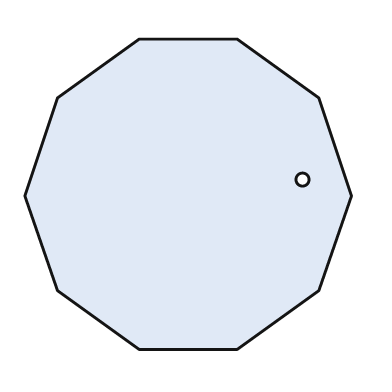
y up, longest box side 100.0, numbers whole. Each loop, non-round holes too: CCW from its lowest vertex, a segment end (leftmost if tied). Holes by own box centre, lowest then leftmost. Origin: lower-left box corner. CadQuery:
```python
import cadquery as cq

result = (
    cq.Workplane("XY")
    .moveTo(35.0, 0.0)
    .lineTo(65.0, 0.0)
    .lineTo(90.0, 18.0)
    .lineTo(100.0, 47.0)
    .lineTo(90.0, 77.0)
    .lineTo(65.0, 95.0)
    .lineTo(35.0, 95.0)
    .lineTo(10.0, 77.0)
    .lineTo(0.0, 47.0)
    .lineTo(10.0, 18.0)
    .close()
    .moveTo(85.0, 52.0)
    .circle(2.0)
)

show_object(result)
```